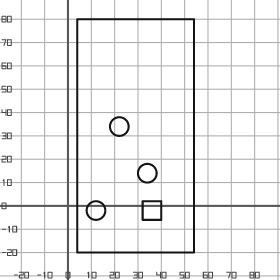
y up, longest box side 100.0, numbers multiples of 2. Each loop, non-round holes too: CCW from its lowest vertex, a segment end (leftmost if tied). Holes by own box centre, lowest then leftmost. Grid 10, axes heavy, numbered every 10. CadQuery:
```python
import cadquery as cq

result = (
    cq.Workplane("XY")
    .moveTo(4.0, -20.0)
    .lineTo(54.0, -20.0)
    .lineTo(54.0, 80.0)
    .lineTo(4.0, 80.0)
    .close()
    .moveTo(12.0, -2.0)
    .circle(4.0)
    .moveTo(32.0, -6.0)
    .lineTo(40.0, -6.0)
    .lineTo(40.0, 2.0)
    .lineTo(32.0, 2.0)
    .close()
    .moveTo(34.0, 14.0)
    .circle(4.0)
    .moveTo(22.0, 34.0)
    .circle(4.0)
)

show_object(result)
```